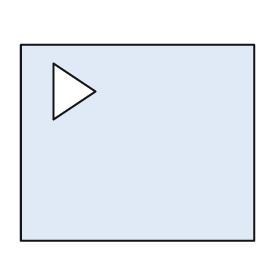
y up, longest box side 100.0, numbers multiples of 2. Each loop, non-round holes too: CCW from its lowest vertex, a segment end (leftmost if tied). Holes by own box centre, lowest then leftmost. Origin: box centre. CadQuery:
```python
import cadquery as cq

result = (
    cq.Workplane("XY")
    .moveTo(-50.0, -42.0)
    .lineTo(50.0, -42.0)
    .lineTo(50.0, 42.0)
    .lineTo(-50.0, 42.0)
    .close()
    .moveTo(-36.0, 10.0)
    .lineTo(-18.0, 22.0)
    .lineTo(-36.0, 34.0)
    .close()
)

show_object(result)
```